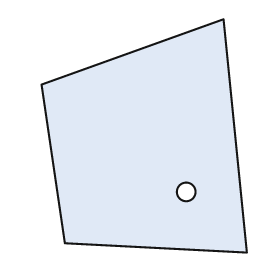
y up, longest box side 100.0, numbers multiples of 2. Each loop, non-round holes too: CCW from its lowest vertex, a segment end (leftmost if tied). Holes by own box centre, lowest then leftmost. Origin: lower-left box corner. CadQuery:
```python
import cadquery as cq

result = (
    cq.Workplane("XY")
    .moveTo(88.0, 0.0)
    .lineTo(78.0, 100.0)
    .lineTo(0.0, 72.0)
    .lineTo(10.0, 4.0)
    .close()
    .moveTo(62.0, 26.0)
    .circle(4.0)
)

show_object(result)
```